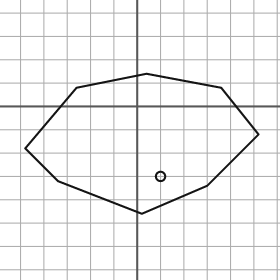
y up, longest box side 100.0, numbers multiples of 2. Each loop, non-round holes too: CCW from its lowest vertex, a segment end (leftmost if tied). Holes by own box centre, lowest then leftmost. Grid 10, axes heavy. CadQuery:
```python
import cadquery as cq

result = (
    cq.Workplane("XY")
    .moveTo(2.0, -46.0)
    .lineTo(30.0, -34.0)
    .lineTo(52.0, -12.0)
    .lineTo(36.0, 8.0)
    .lineTo(4.0, 14.0)
    .lineTo(-26.0, 8.0)
    .lineTo(-48.0, -18.0)
    .lineTo(-34.0, -32.0)
    .close()
    .moveTo(10.0, -30.0)
    .circle(2.0)
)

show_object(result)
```